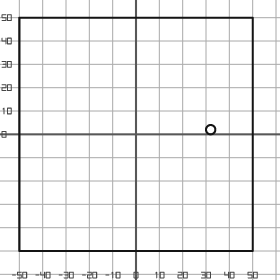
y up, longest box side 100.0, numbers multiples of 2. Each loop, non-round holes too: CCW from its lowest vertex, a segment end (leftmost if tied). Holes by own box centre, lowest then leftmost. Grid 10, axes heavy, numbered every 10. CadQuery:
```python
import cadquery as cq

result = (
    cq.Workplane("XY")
    .moveTo(-50.0, -50.0)
    .lineTo(50.0, -50.0)
    .lineTo(50.0, 50.0)
    .lineTo(-50.0, 50.0)
    .close()
    .moveTo(32.0, 2.0)
    .circle(2.0)
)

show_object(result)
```